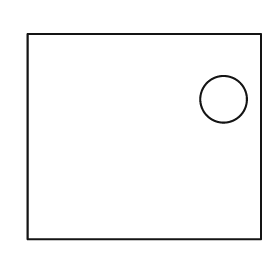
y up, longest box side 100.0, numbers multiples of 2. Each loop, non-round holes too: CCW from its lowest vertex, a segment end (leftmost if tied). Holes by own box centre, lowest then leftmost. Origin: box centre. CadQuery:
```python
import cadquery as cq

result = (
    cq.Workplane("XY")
    .moveTo(-50.0, -44.0)
    .lineTo(50.0, -44.0)
    .lineTo(50.0, 44.0)
    .lineTo(-50.0, 44.0)
    .close()
    .moveTo(34.0, 16.0)
    .circle(10.0)
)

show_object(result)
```